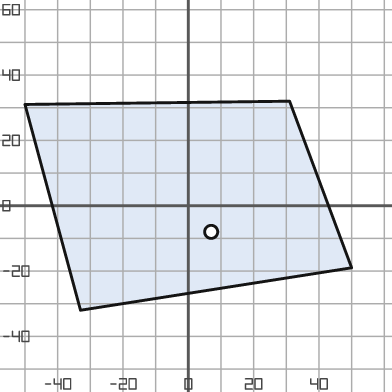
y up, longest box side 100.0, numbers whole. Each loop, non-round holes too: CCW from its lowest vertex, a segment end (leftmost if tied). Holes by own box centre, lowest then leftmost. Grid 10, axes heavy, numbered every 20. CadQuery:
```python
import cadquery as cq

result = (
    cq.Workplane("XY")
    .moveTo(-33.0, -32.0)
    .lineTo(50.0, -19.0)
    .lineTo(31.0, 32.0)
    .lineTo(-50.0, 31.0)
    .close()
    .moveTo(7.0, -8.0)
    .circle(2.0)
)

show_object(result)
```